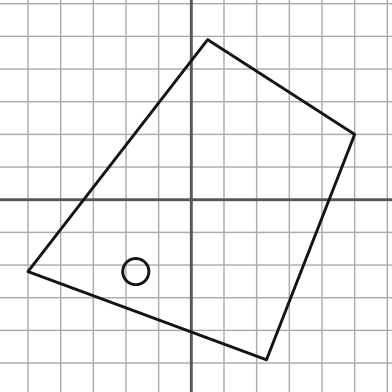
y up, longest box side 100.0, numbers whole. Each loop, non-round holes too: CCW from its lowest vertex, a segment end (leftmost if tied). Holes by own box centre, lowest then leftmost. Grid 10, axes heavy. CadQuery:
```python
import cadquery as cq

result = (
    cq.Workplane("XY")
    .moveTo(23.0, -49.0)
    .lineTo(50.0, 20.0)
    .lineTo(5.0, 49.0)
    .lineTo(-50.0, -22.0)
    .close()
    .moveTo(-17.0, -22.0)
    .circle(4.0)
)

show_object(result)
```